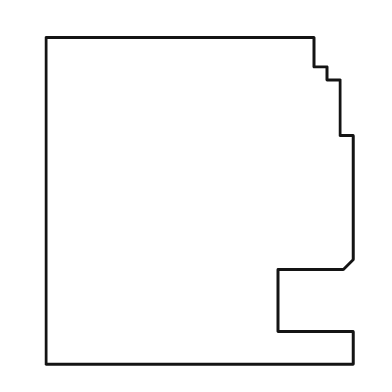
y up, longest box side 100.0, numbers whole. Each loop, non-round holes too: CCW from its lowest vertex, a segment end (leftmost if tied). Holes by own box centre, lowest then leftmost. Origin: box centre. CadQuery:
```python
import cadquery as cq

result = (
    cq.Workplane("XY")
    .moveTo(-47.0, -50.0)
    .lineTo(47.0, -50.0)
    .lineTo(47.0, -40.0)
    .lineTo(24.0, -40.0)
    .lineTo(24.0, -21.0)
    .lineTo(44.0, -21.0)
    .lineTo(47.0, -18.0)
    .lineTo(47.0, 20.0)
    .lineTo(43.0, 20.0)
    .lineTo(43.0, 37.0)
    .lineTo(39.0, 37.0)
    .lineTo(39.0, 41.0)
    .lineTo(35.0, 41.0)
    .lineTo(35.0, 50.0)
    .lineTo(-47.0, 50.0)
    .close()
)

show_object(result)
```